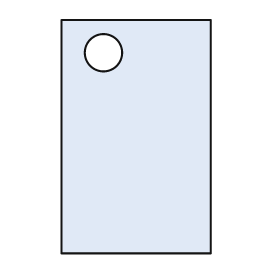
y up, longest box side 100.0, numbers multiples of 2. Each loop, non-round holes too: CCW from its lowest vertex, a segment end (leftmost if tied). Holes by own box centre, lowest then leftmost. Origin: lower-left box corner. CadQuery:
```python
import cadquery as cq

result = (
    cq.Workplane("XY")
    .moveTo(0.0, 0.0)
    .lineTo(64.0, 0.0)
    .lineTo(64.0, 100.0)
    .lineTo(0.0, 100.0)
    .close()
    .moveTo(18.0, 86.0)
    .circle(8.0)
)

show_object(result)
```